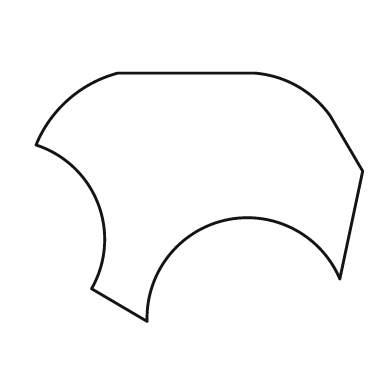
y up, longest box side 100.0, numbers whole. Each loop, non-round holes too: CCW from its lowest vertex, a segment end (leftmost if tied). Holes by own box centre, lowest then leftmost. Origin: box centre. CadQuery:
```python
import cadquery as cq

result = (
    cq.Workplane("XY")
    .moveTo(-16.0, -38.0)
    .threePointArc((8.0, -7.0), (43.0, -25.0))
    .lineTo(50.0, 8.0)
    .lineTo(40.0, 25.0)
    .threePointArc((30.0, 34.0), (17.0, 38.0))
    .lineTo(-25.0, 38.0)
    .threePointArc((-40.0, 30.0), (-50.0, 16.0))
    .threePointArc((-31.0, -2.0), (-33.0, -28.0))
    .close()
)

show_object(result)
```